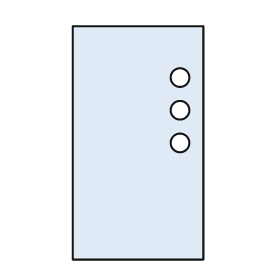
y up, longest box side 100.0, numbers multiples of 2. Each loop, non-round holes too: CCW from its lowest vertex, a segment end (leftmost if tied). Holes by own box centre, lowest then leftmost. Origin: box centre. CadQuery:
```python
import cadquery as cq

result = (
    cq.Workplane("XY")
    .moveTo(-28.0, -50.0)
    .lineTo(28.0, -50.0)
    .lineTo(28.0, 50.0)
    .lineTo(-28.0, 50.0)
    .close()
    .moveTo(18.0, 0.0)
    .circle(4.0)
    .moveTo(18.0, 14.0)
    .circle(4.0)
    .moveTo(18.0, 28.0)
    .circle(4.0)
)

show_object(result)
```